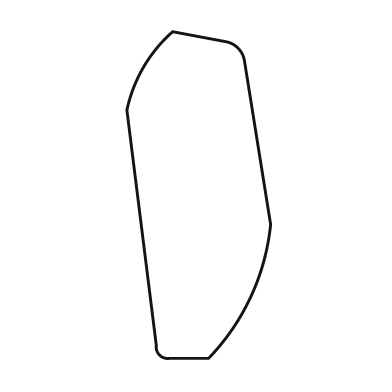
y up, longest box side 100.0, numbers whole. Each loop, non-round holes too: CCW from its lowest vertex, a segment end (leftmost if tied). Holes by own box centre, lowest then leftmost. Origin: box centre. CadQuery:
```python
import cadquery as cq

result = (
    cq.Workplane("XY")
    .moveTo(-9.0, -50.0)
    .lineTo(3.0, -50.0)
    .threePointArc((16.0, -31.0), (22.0, -9.0))
    .lineTo(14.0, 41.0)
    .threePointArc((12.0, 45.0), (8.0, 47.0))
    .lineTo(-8.0, 50.0)
    .threePointArc((-17.0, 39.0), (-22.0, 26.0))
    .lineTo(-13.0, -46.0)
    .threePointArc((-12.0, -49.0), (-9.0, -50.0))
    .close()
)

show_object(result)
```